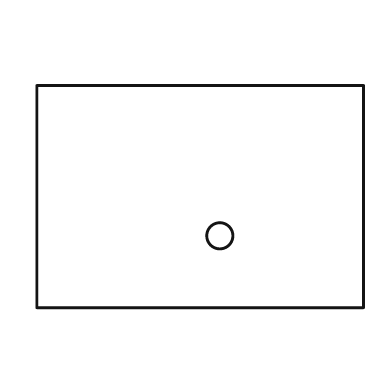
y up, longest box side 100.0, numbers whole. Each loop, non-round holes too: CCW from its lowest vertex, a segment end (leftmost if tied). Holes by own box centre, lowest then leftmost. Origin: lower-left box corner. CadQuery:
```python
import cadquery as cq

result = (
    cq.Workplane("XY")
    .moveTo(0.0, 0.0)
    .lineTo(100.0, 0.0)
    .lineTo(100.0, 68.0)
    .lineTo(0.0, 68.0)
    .close()
    .moveTo(56.0, 22.0)
    .circle(4.0)
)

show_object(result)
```